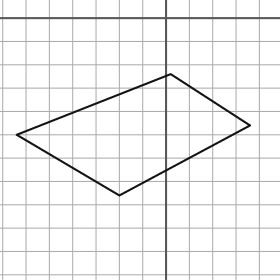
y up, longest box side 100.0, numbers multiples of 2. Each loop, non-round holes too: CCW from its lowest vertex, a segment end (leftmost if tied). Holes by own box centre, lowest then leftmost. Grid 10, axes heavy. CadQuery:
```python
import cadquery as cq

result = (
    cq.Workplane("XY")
    .moveTo(-20.0, -76.0)
    .lineTo(36.0, -46.0)
    .lineTo(2.0, -24.0)
    .lineTo(-64.0, -50.0)
    .close()
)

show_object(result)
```